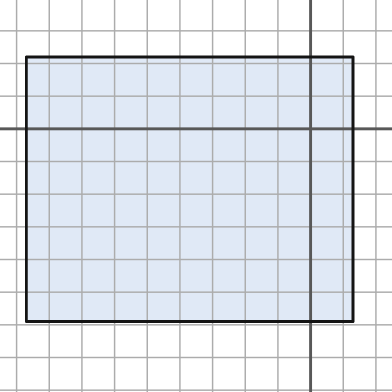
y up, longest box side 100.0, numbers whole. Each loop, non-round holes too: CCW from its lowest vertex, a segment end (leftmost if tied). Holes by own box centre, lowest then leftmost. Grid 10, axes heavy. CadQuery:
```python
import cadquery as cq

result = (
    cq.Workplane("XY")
    .moveTo(-87.0, -59.0)
    .lineTo(13.0, -59.0)
    .lineTo(13.0, 22.0)
    .lineTo(-87.0, 22.0)
    .close()
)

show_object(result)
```